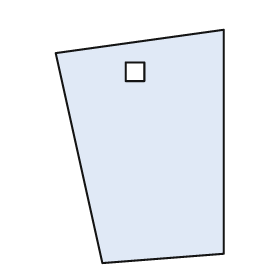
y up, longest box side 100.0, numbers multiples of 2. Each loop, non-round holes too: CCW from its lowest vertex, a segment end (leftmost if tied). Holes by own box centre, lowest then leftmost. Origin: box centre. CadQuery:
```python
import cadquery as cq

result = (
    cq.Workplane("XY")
    .moveTo(-16.0, -50.0)
    .lineTo(36.0, -46.0)
    .lineTo(36.0, 50.0)
    .lineTo(-36.0, 40.0)
    .close()
    .moveTo(-6.0, 28.0)
    .lineTo(2.0, 28.0)
    .lineTo(2.0, 36.0)
    .lineTo(-6.0, 36.0)
    .close()
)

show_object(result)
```